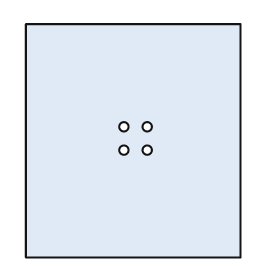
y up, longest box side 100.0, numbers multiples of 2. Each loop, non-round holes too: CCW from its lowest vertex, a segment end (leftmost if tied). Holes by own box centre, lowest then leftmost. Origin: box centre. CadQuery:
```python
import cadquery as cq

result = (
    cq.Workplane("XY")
    .moveTo(-46.0, -50.0)
    .lineTo(46.0, -50.0)
    .lineTo(46.0, 50.0)
    .lineTo(-46.0, 50.0)
    .close()
    .moveTo(-4.0, -4.0)
    .circle(2.0)
    .moveTo(6.0, -4.0)
    .circle(2.0)
    .moveTo(-4.0, 6.0)
    .circle(2.0)
    .moveTo(6.0, 6.0)
    .circle(2.0)
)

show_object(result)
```